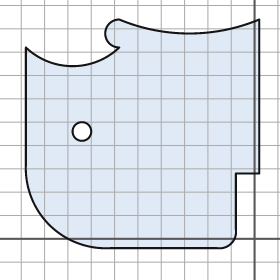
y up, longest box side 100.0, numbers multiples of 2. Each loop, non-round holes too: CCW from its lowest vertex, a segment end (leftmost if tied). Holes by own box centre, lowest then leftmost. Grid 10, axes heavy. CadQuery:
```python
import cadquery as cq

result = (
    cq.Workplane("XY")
    .moveTo(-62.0, -4.0)
    .lineTo(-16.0, -4.0)
    .threePointArc((-10.0, -2.0), (-8.0, 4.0))
    .lineTo(-8.0, 28.0)
    .lineTo(2.0, 28.0)
    .lineTo(2.0, 94.0)
    .threePointArc((-28.0, 88.0), (-58.0, 94.0))
    .threePointArc((-64.0, 88.0), (-58.0, 82.0))
    .threePointArc((-78.0, 74.0), (-98.0, 82.0))
    .lineTo(-98.0, 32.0)
    .threePointArc((-88.0, 6.0), (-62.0, -4.0))
    .close()
    .moveTo(-74.0, 46.0)
    .circle(4.0)
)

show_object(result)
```